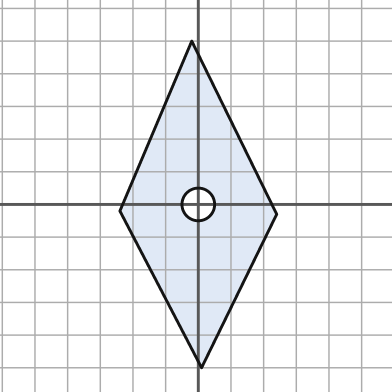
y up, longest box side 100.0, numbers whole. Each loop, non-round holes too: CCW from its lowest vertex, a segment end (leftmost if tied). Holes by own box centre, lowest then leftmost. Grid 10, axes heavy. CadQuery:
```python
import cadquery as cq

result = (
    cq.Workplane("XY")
    .moveTo(1.0, -50.0)
    .lineTo(24.0, -3.0)
    .lineTo(-2.0, 50.0)
    .lineTo(-24.0, -2.0)
    .close()
    .moveTo(0.0, 0.0)
    .circle(5.0)
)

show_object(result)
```